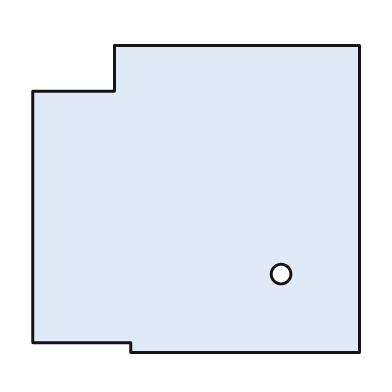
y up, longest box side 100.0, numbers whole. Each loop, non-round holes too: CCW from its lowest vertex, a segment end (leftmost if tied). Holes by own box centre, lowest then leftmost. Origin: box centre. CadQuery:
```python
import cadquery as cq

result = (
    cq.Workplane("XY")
    .moveTo(-20.0, -47.0)
    .lineTo(50.0, -47.0)
    .lineTo(50.0, 47.0)
    .lineTo(-25.0, 47.0)
    .lineTo(-25.0, 33.0)
    .lineTo(-50.0, 33.0)
    .lineTo(-50.0, -44.0)
    .lineTo(-20.0, -44.0)
    .close()
    .moveTo(26.0, -23.0)
    .circle(3.0)
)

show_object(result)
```